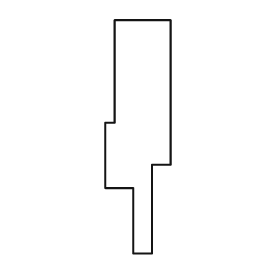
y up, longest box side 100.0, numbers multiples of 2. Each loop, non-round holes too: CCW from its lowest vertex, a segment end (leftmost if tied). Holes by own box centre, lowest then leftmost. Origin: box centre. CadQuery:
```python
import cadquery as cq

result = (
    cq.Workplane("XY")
    .moveTo(-2.0, -50.0)
    .lineTo(6.0, -50.0)
    .lineTo(6.0, -12.0)
    .lineTo(14.0, -12.0)
    .lineTo(14.0, 50.0)
    .lineTo(-10.0, 50.0)
    .lineTo(-10.0, 6.0)
    .lineTo(-14.0, 6.0)
    .lineTo(-14.0, -22.0)
    .lineTo(-2.0, -22.0)
    .close()
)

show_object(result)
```